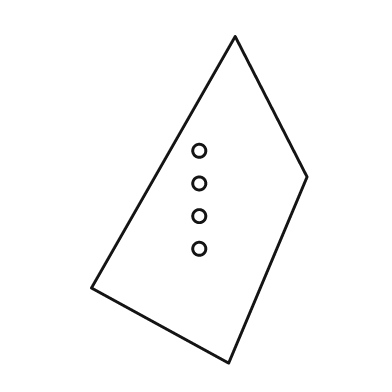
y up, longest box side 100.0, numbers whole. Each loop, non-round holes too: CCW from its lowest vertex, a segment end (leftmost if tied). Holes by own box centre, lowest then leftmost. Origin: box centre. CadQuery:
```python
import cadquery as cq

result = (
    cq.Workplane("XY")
    .moveTo(9.0, -50.0)
    .lineTo(33.0, 7.0)
    .lineTo(11.0, 50.0)
    .lineTo(-33.0, -27.0)
    .close()
    .moveTo(0.0, -15.0)
    .circle(2.0)
    .moveTo(0.0, -5.0)
    .circle(2.0)
    .moveTo(0.0, 5.0)
    .circle(2.0)
    .moveTo(0.0, 15.0)
    .circle(2.0)
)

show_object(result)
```